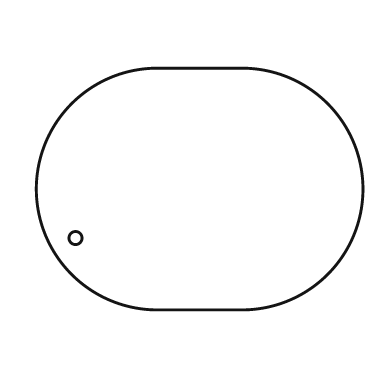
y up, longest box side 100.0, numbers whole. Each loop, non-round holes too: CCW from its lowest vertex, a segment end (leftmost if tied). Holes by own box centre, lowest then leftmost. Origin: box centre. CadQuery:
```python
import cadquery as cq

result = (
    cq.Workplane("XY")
    .moveTo(-13.0, -37.0)
    .lineTo(13.0, -37.0)
    .threePointArc((50.0, 0.0), (13.0, 37.0))
    .lineTo(-13.0, 37.0)
    .threePointArc((-50.0, 0.0), (-13.0, -37.0))
    .close()
    .moveTo(-38.0, -15.0)
    .circle(2.0)
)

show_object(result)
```